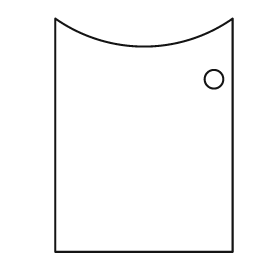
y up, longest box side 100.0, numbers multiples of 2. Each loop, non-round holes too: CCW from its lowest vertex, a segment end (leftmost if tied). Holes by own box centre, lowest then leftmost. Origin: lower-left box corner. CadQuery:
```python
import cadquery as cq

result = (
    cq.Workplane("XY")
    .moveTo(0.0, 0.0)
    .lineTo(76.0, 0.0)
    .lineTo(76.0, 100.0)
    .threePointArc((38.0, 88.0), (0.0, 100.0))
    .close()
    .moveTo(68.0, 74.0)
    .circle(4.0)
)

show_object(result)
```